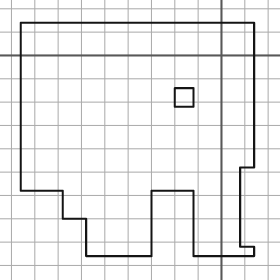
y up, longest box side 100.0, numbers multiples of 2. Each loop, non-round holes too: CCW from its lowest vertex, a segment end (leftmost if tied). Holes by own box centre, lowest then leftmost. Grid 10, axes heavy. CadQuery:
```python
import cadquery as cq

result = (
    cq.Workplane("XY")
    .moveTo(-58.0, -86.0)
    .lineTo(-30.0, -86.0)
    .lineTo(-30.0, -58.0)
    .lineTo(-12.0, -58.0)
    .lineTo(-12.0, -86.0)
    .lineTo(14.0, -86.0)
    .lineTo(14.0, -82.0)
    .lineTo(8.0, -82.0)
    .lineTo(8.0, -48.0)
    .lineTo(14.0, -48.0)
    .lineTo(14.0, 14.0)
    .lineTo(-86.0, 14.0)
    .lineTo(-86.0, -58.0)
    .lineTo(-68.0, -58.0)
    .lineTo(-68.0, -70.0)
    .lineTo(-58.0, -70.0)
    .close()
    .moveTo(-20.0, -22.0)
    .lineTo(-12.0, -22.0)
    .lineTo(-12.0, -14.0)
    .lineTo(-20.0, -14.0)
    .close()
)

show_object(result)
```